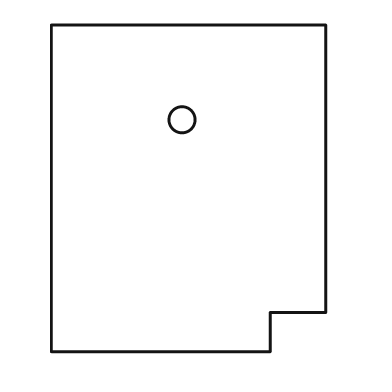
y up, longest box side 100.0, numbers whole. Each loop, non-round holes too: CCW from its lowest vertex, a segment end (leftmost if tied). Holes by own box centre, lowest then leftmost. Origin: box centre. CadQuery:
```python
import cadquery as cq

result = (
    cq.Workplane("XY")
    .moveTo(-42.0, -50.0)
    .lineTo(25.0, -50.0)
    .lineTo(25.0, -38.0)
    .lineTo(42.0, -38.0)
    .lineTo(42.0, 50.0)
    .lineTo(-42.0, 50.0)
    .close()
    .moveTo(-2.0, 21.0)
    .circle(4.0)
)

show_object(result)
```